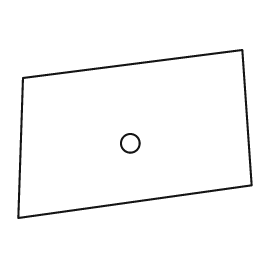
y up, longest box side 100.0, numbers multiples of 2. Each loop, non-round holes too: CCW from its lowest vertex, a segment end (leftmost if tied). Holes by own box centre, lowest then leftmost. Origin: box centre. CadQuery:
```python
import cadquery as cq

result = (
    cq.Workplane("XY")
    .moveTo(-50.0, -36.0)
    .lineTo(50.0, -22.0)
    .lineTo(46.0, 36.0)
    .lineTo(-48.0, 24.0)
    .close()
    .moveTo(-2.0, -4.0)
    .circle(4.0)
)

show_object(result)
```